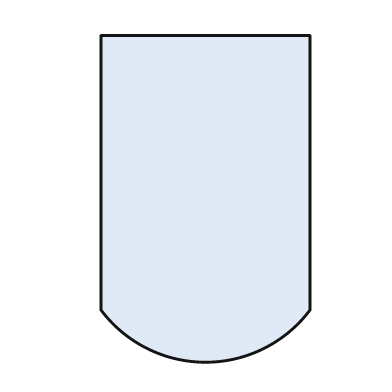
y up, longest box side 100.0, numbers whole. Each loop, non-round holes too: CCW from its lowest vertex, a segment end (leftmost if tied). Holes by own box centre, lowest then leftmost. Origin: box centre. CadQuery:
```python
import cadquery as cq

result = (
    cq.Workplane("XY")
    .moveTo(-32.0, -34.0)
    .threePointArc((0.0, -50.0), (32.0, -34.0))
    .lineTo(32.0, 50.0)
    .lineTo(-32.0, 50.0)
    .close()
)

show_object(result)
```